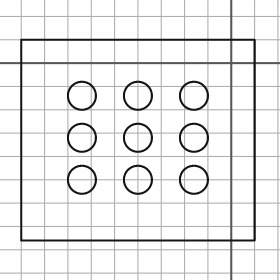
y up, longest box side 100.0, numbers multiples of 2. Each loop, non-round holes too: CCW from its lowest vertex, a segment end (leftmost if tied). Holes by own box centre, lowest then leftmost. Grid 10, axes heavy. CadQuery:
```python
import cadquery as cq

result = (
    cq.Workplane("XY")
    .moveTo(-90.0, -76.0)
    .lineTo(10.0, -76.0)
    .lineTo(10.0, 10.0)
    .lineTo(-90.0, 10.0)
    .close()
    .moveTo(-64.0, -50.0)
    .circle(6.0)
    .moveTo(-40.0, -50.0)
    .circle(6.0)
    .moveTo(-16.0, -50.0)
    .circle(6.0)
    .moveTo(-64.0, -32.0)
    .circle(6.0)
    .moveTo(-40.0, -32.0)
    .circle(6.0)
    .moveTo(-16.0, -32.0)
    .circle(6.0)
    .moveTo(-64.0, -14.0)
    .circle(6.0)
    .moveTo(-40.0, -14.0)
    .circle(6.0)
    .moveTo(-16.0, -14.0)
    .circle(6.0)
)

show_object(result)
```